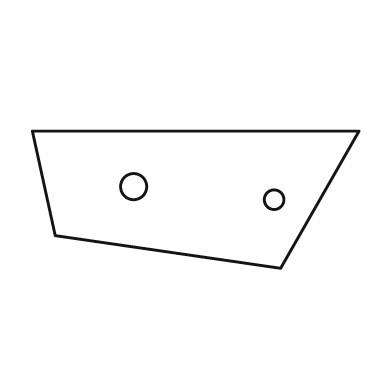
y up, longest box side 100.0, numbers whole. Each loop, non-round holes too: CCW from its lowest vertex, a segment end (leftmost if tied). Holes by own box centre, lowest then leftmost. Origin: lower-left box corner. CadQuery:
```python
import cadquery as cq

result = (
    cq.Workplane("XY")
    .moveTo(76.0, 0.0)
    .lineTo(100.0, 42.0)
    .lineTo(0.0, 42.0)
    .lineTo(7.0, 10.0)
    .close()
    .moveTo(74.0, 21.0)
    .circle(3.0)
    .moveTo(31.0, 25.0)
    .circle(4.0)
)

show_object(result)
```